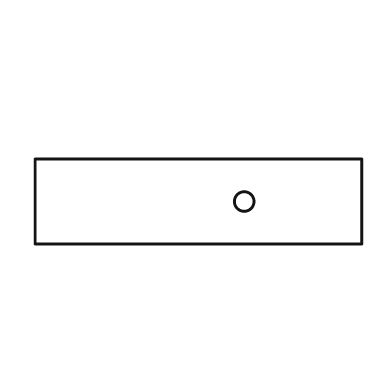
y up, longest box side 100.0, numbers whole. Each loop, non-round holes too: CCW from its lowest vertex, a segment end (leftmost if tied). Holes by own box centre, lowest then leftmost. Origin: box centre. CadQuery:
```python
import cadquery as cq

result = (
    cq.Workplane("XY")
    .moveTo(-50.0, -13.0)
    .lineTo(50.0, -13.0)
    .lineTo(50.0, 13.0)
    .lineTo(-50.0, 13.0)
    .close()
    .moveTo(14.0, 0.0)
    .circle(3.0)
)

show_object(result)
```